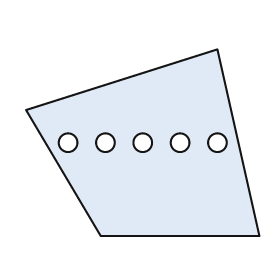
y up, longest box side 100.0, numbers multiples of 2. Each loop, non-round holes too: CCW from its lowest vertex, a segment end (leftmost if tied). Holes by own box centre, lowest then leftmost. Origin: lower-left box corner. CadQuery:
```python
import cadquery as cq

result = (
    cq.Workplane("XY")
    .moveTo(32.0, 0.0)
    .lineTo(100.0, 0.0)
    .lineTo(82.0, 80.0)
    .lineTo(0.0, 54.0)
    .close()
    .moveTo(18.0, 40.0)
    .circle(4.0)
    .moveTo(34.0, 40.0)
    .circle(4.0)
    .moveTo(50.0, 40.0)
    .circle(4.0)
    .moveTo(66.0, 40.0)
    .circle(4.0)
    .moveTo(82.0, 40.0)
    .circle(4.0)
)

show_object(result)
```